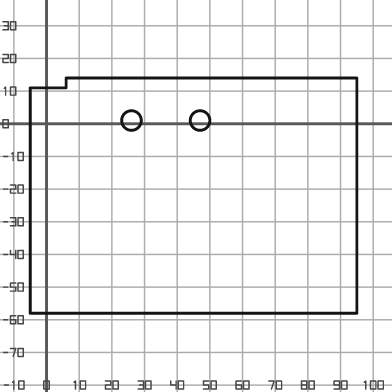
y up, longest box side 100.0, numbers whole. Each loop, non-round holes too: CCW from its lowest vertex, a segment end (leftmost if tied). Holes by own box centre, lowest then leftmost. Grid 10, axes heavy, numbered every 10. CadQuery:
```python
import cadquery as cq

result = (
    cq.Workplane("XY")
    .moveTo(-5.0, -58.0)
    .lineTo(95.0, -58.0)
    .lineTo(95.0, 14.0)
    .lineTo(6.0, 14.0)
    .lineTo(6.0, 11.0)
    .lineTo(-5.0, 11.0)
    .close()
    .moveTo(26.0, 1.0)
    .circle(3.0)
    .moveTo(47.0, 1.0)
    .circle(3.0)
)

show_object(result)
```